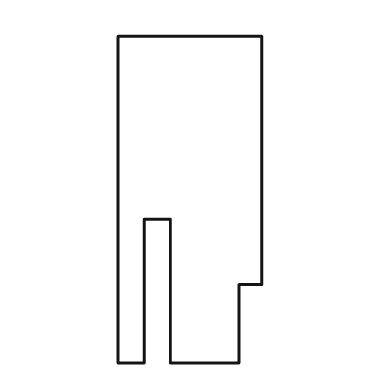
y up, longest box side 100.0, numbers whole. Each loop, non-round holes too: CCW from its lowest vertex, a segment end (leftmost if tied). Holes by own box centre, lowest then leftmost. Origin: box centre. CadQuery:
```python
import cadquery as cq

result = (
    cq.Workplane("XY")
    .moveTo(-22.0, -50.0)
    .lineTo(-14.0, -50.0)
    .lineTo(-14.0, -6.0)
    .lineTo(-6.0, -6.0)
    .lineTo(-6.0, -50.0)
    .lineTo(15.0, -50.0)
    .lineTo(15.0, -26.0)
    .lineTo(22.0, -26.0)
    .lineTo(22.0, 50.0)
    .lineTo(-22.0, 50.0)
    .close()
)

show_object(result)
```